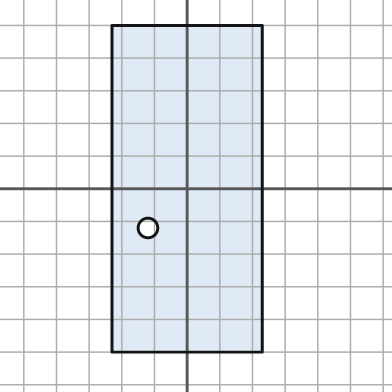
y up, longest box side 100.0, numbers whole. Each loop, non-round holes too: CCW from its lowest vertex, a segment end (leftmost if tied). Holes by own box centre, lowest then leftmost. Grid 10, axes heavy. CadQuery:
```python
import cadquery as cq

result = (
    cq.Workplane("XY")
    .moveTo(-23.0, -50.0)
    .lineTo(23.0, -50.0)
    .lineTo(23.0, 50.0)
    .lineTo(-23.0, 50.0)
    .close()
    .moveTo(-12.0, -12.0)
    .circle(3.0)
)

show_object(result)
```